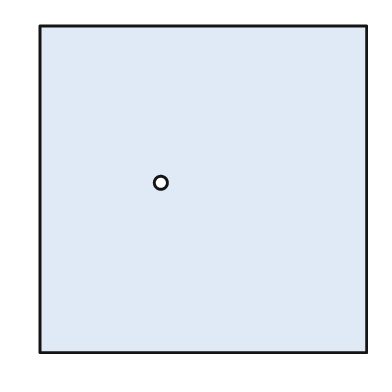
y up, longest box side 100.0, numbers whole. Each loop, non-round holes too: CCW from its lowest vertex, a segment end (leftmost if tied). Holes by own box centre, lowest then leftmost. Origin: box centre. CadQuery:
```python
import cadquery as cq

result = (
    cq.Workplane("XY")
    .moveTo(-50.0, -50.0)
    .lineTo(50.0, -50.0)
    .lineTo(50.0, 50.0)
    .lineTo(-50.0, 50.0)
    .close()
    .moveTo(-13.0, 2.0)
    .circle(2.0)
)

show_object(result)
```